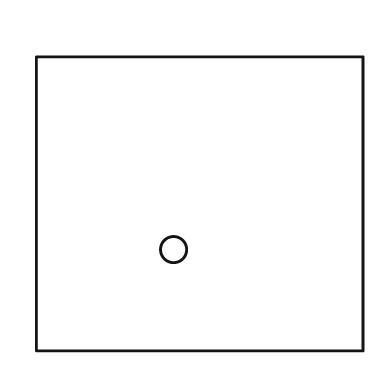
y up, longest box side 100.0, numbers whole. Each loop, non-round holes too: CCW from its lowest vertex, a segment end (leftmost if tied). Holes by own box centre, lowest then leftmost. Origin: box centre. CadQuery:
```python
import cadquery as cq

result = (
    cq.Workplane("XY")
    .moveTo(-50.0, -45.0)
    .lineTo(50.0, -45.0)
    .lineTo(50.0, 45.0)
    .lineTo(-50.0, 45.0)
    .close()
    .moveTo(-8.0, -14.0)
    .circle(4.0)
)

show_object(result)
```